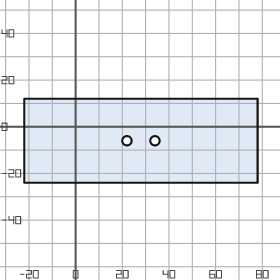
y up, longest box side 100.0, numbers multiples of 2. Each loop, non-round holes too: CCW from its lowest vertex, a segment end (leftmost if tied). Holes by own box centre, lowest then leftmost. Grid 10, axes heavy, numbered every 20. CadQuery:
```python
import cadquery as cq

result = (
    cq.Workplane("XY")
    .moveTo(-22.0, -24.0)
    .lineTo(78.0, -24.0)
    .lineTo(78.0, 12.0)
    .lineTo(-22.0, 12.0)
    .close()
    .moveTo(22.0, -6.0)
    .circle(2.0)
    .moveTo(34.0, -6.0)
    .circle(2.0)
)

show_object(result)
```